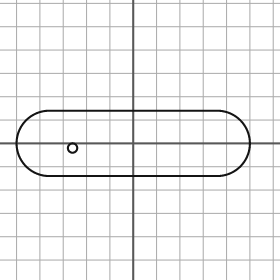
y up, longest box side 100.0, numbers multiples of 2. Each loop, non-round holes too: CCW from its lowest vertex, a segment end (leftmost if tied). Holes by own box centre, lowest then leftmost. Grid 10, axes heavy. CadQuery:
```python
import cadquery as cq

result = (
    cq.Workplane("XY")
    .moveTo(-36.0, -14.0)
    .lineTo(36.0, -14.0)
    .threePointArc((50.0, 0.0), (36.0, 14.0))
    .lineTo(-36.0, 14.0)
    .threePointArc((-50.0, 0.0), (-36.0, -14.0))
    .close()
    .moveTo(-26.0, -2.0)
    .circle(2.0)
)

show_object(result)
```